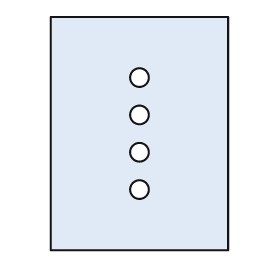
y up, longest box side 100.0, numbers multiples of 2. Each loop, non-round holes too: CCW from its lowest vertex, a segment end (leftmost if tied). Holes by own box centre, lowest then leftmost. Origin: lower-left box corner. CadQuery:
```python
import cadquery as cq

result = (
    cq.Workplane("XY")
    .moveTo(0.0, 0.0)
    .lineTo(76.0, 0.0)
    .lineTo(76.0, 100.0)
    .lineTo(0.0, 100.0)
    .close()
    .moveTo(38.0, 26.0)
    .circle(4.0)
    .moveTo(38.0, 42.0)
    .circle(4.0)
    .moveTo(38.0, 58.0)
    .circle(4.0)
    .moveTo(38.0, 74.0)
    .circle(4.0)
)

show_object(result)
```